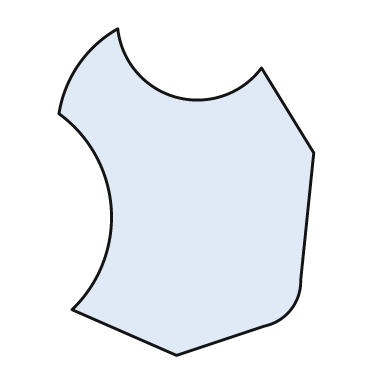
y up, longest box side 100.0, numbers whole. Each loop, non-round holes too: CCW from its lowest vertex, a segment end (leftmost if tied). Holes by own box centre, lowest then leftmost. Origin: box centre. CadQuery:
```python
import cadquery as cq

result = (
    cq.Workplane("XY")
    .moveTo(-3.0, -50.0)
    .lineTo(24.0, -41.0)
    .threePointArc((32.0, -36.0), (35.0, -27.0))
    .lineTo(39.0, 12.0)
    .lineTo(23.0, 38.0)
    .threePointArc((-3.0, 29.0), (-21.0, 50.0))
    .threePointArc((-33.0, 39.0), (-39.0, 24.0))
    .threePointArc((-23.0, -5.0), (-35.0, -36.0))
    .close()
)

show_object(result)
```